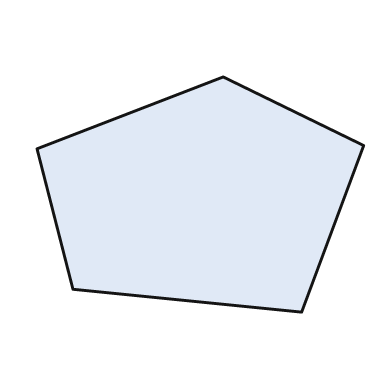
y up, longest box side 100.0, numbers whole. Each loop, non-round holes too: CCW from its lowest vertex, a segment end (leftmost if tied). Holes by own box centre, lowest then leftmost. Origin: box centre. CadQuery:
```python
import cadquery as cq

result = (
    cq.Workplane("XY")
    .moveTo(31.0, -36.0)
    .lineTo(50.0, 15.0)
    .lineTo(7.0, 36.0)
    .lineTo(-50.0, 14.0)
    .lineTo(-39.0, -29.0)
    .close()
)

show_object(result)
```